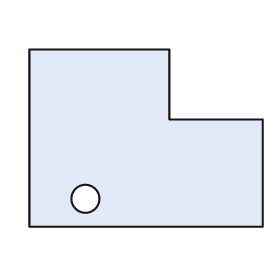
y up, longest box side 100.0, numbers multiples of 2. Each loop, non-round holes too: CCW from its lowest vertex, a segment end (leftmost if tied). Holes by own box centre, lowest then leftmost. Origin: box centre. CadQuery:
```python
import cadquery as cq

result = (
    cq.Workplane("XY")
    .moveTo(-50.0, -38.0)
    .lineTo(50.0, -38.0)
    .lineTo(50.0, 8.0)
    .lineTo(10.0, 8.0)
    .lineTo(10.0, 38.0)
    .lineTo(-50.0, 38.0)
    .close()
    .moveTo(-26.0, -26.0)
    .circle(6.0)
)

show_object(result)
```